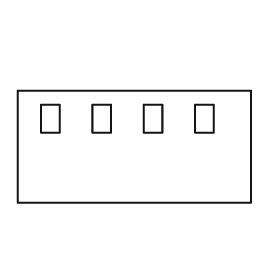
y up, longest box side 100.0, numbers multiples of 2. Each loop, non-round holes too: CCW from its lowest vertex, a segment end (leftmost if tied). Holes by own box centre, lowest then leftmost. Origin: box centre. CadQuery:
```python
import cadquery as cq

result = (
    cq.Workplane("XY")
    .moveTo(-50.0, -24.0)
    .lineTo(50.0, -24.0)
    .lineTo(50.0, 24.0)
    .lineTo(-50.0, 24.0)
    .close()
    .moveTo(-40.0, 6.0)
    .lineTo(-32.0, 6.0)
    .lineTo(-32.0, 18.0)
    .lineTo(-40.0, 18.0)
    .close()
    .moveTo(-18.0, 6.0)
    .lineTo(-10.0, 6.0)
    .lineTo(-10.0, 18.0)
    .lineTo(-18.0, 18.0)
    .close()
    .moveTo(4.0, 6.0)
    .lineTo(12.0, 6.0)
    .lineTo(12.0, 18.0)
    .lineTo(4.0, 18.0)
    .close()
    .moveTo(26.0, 6.0)
    .lineTo(34.0, 6.0)
    .lineTo(34.0, 18.0)
    .lineTo(26.0, 18.0)
    .close()
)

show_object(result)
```